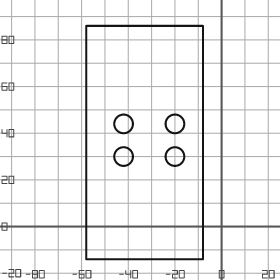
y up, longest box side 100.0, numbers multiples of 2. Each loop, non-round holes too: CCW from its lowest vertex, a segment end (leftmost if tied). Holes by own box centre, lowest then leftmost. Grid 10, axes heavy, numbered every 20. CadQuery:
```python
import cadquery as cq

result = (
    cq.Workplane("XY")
    .moveTo(-58.0, -14.0)
    .lineTo(-8.0, -14.0)
    .lineTo(-8.0, 86.0)
    .lineTo(-58.0, 86.0)
    .close()
    .moveTo(-42.0, 30.0)
    .circle(4.0)
    .moveTo(-20.0, 30.0)
    .circle(4.0)
    .moveTo(-42.0, 44.0)
    .circle(4.0)
    .moveTo(-20.0, 44.0)
    .circle(4.0)
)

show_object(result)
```